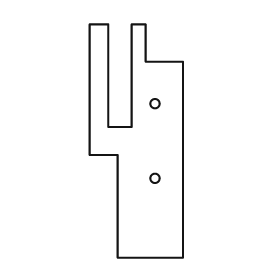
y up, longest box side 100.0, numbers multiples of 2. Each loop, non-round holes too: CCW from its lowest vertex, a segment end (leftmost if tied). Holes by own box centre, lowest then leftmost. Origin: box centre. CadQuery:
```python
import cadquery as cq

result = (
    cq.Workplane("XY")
    .moveTo(-8.0, -50.0)
    .lineTo(20.0, -50.0)
    .lineTo(20.0, 34.0)
    .lineTo(4.0, 34.0)
    .lineTo(4.0, 50.0)
    .lineTo(-2.0, 50.0)
    .lineTo(-2.0, 6.0)
    .lineTo(-12.0, 6.0)
    .lineTo(-12.0, 50.0)
    .lineTo(-20.0, 50.0)
    .lineTo(-20.0, -6.0)
    .lineTo(-8.0, -6.0)
    .close()
    .moveTo(8.0, -16.0)
    .circle(2.0)
    .moveTo(8.0, 16.0)
    .circle(2.0)
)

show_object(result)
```